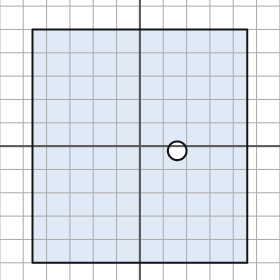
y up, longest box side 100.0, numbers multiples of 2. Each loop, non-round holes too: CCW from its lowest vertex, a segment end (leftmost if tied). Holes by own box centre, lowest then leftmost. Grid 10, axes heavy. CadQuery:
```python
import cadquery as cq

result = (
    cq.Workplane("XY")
    .moveTo(-46.0, -50.0)
    .lineTo(46.0, -50.0)
    .lineTo(46.0, 50.0)
    .lineTo(-46.0, 50.0)
    .close()
    .moveTo(16.0, -2.0)
    .circle(4.0)
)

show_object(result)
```